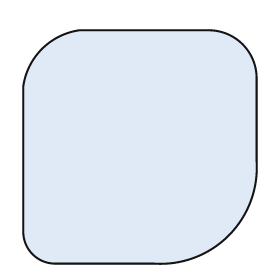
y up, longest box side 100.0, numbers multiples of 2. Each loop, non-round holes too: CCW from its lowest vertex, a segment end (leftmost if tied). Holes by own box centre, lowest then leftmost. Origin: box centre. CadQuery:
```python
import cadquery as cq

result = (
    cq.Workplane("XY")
    .moveTo(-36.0, -50.0)
    .lineTo(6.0, -50.0)
    .threePointArc((38.0, -38.0), (50.0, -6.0))
    .lineTo(50.0, 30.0)
    .threePointArc((44.0, 44.0), (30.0, 50.0))
    .lineTo(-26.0, 50.0)
    .threePointArc((-42.0, 42.0), (-50.0, 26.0))
    .lineTo(-50.0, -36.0)
    .threePointArc((-46.0, -46.0), (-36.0, -50.0))
    .close()
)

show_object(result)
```